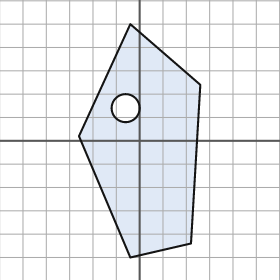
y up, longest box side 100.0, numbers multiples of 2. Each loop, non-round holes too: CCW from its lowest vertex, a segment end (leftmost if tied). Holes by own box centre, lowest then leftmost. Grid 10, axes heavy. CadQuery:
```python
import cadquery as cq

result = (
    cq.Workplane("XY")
    .moveTo(-4.0, -50.0)
    .lineTo(22.0, -44.0)
    .lineTo(26.0, 24.0)
    .lineTo(-4.0, 50.0)
    .lineTo(-26.0, 2.0)
    .close()
    .moveTo(-6.0, 14.0)
    .circle(6.0)
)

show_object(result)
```